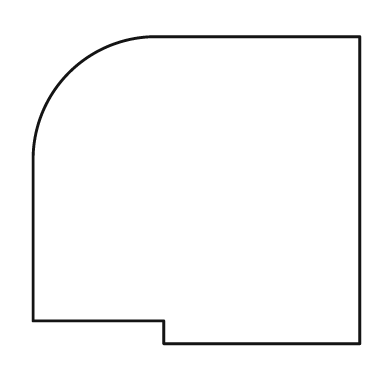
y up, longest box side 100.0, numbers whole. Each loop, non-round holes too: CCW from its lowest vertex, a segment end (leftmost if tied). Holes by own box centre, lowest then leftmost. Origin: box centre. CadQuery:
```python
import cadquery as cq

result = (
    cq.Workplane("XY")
    .moveTo(-10.0, -47.0)
    .lineTo(50.0, -47.0)
    .lineTo(50.0, 47.0)
    .lineTo(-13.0, 47.0)
    .threePointArc((-39.0, 36.0), (-50.0, 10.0))
    .lineTo(-50.0, -40.0)
    .lineTo(-10.0, -40.0)
    .close()
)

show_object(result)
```